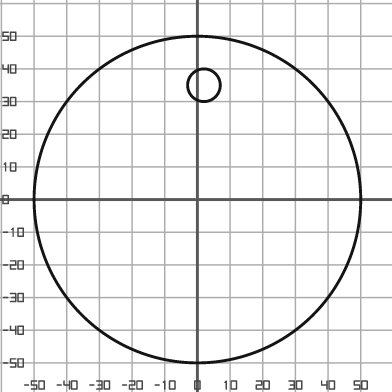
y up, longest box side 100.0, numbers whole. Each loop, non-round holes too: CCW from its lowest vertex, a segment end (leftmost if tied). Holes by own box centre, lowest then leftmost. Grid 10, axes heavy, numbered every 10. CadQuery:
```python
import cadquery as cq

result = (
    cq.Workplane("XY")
    .moveTo(0.0, 0.0)
    .circle(50.0)
    .moveTo(2.0, 35.0)
    .circle(5.0)
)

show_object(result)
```